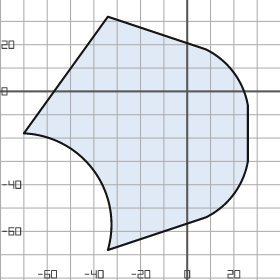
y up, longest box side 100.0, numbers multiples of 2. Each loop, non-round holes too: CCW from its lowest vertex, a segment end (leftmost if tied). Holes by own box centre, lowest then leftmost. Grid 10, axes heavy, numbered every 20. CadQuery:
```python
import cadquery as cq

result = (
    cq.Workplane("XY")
    .moveTo(-34.0, -68.0)
    .lineTo(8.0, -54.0)
    .threePointArc((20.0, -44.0), (26.0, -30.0))
    .lineTo(26.0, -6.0)
    .threePointArc((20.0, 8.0), (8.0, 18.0))
    .lineTo(-34.0, 32.0)
    .lineTo(-70.0, -18.0)
    .threePointArc((-40.0, -34.0), (-34.0, -68.0))
    .close()
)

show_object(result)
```